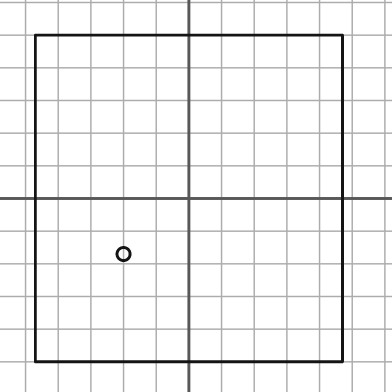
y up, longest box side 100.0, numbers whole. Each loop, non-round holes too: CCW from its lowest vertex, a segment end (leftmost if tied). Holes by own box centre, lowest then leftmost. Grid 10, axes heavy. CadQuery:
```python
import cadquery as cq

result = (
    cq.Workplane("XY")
    .moveTo(-47.0, -50.0)
    .lineTo(47.0, -50.0)
    .lineTo(47.0, 50.0)
    .lineTo(-47.0, 50.0)
    .close()
    .moveTo(-20.0, -17.0)
    .circle(2.0)
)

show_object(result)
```